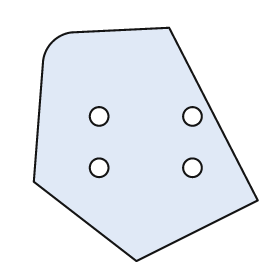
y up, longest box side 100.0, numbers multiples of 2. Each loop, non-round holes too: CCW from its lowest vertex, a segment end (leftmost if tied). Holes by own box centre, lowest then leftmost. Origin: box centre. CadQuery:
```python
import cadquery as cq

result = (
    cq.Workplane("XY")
    .moveTo(-4.0, -50.0)
    .lineTo(48.0, -24.0)
    .lineTo(10.0, 50.0)
    .lineTo(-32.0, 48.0)
    .threePointArc((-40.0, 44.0), (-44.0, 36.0))
    .lineTo(-48.0, -16.0)
    .close()
    .moveTo(-20.0, -10.0)
    .circle(4.0)
    .moveTo(20.0, -10.0)
    .circle(4.0)
    .moveTo(-20.0, 12.0)
    .circle(4.0)
    .moveTo(20.0, 12.0)
    .circle(4.0)
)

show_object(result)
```